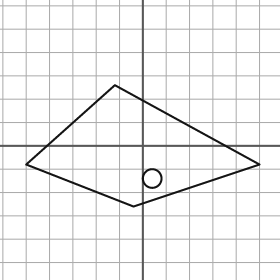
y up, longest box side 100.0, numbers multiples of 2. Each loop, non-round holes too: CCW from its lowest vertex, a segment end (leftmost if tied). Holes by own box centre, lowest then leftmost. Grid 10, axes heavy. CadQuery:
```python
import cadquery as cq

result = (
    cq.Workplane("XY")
    .moveTo(-4.0, -26.0)
    .lineTo(50.0, -8.0)
    .lineTo(-12.0, 26.0)
    .lineTo(-50.0, -8.0)
    .close()
    .moveTo(4.0, -14.0)
    .circle(4.0)
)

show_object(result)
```